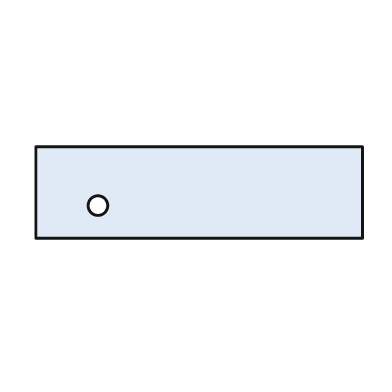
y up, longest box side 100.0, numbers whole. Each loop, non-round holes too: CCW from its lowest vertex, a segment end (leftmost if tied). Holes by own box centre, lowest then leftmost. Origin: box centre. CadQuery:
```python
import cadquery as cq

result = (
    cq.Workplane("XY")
    .moveTo(-50.0, -14.0)
    .lineTo(50.0, -14.0)
    .lineTo(50.0, 14.0)
    .lineTo(-50.0, 14.0)
    .close()
    .moveTo(-31.0, -4.0)
    .circle(3.0)
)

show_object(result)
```